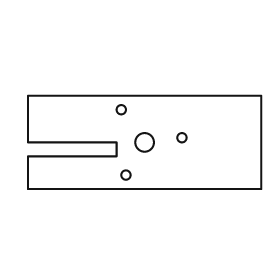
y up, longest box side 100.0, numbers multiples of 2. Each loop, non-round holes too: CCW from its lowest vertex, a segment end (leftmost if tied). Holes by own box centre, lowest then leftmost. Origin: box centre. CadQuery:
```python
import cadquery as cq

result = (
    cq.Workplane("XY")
    .moveTo(-50.0, -20.0)
    .lineTo(50.0, -20.0)
    .lineTo(50.0, 20.0)
    .lineTo(-50.0, 20.0)
    .lineTo(-50.0, 0.0)
    .lineTo(-12.0, 0.0)
    .lineTo(-12.0, -6.0)
    .lineTo(-50.0, -6.0)
    .close()
    .moveTo(-8.0, -14.0)
    .circle(2.0)
    .moveTo(0.0, 0.0)
    .circle(4.0)
    .moveTo(16.0, 2.0)
    .circle(2.0)
    .moveTo(-10.0, 14.0)
    .circle(2.0)
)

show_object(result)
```